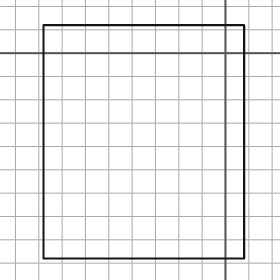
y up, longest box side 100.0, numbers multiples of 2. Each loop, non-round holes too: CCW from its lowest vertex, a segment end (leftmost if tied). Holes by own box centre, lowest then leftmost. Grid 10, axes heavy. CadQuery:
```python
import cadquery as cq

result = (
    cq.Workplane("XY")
    .moveTo(-78.0, -88.0)
    .lineTo(8.0, -88.0)
    .lineTo(8.0, 12.0)
    .lineTo(-78.0, 12.0)
    .close()
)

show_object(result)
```